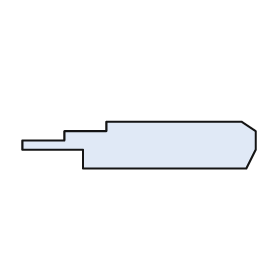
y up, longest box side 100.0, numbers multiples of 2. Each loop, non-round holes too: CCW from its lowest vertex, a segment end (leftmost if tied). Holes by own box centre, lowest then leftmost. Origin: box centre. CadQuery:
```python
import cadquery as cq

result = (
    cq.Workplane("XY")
    .moveTo(-24.0, -10.0)
    .lineTo(46.0, -10.0)
    .lineTo(50.0, -2.0)
    .lineTo(50.0, 6.0)
    .lineTo(44.0, 10.0)
    .lineTo(-14.0, 10.0)
    .lineTo(-14.0, 6.0)
    .lineTo(-32.0, 6.0)
    .lineTo(-32.0, 2.0)
    .lineTo(-50.0, 2.0)
    .lineTo(-50.0, -2.0)
    .lineTo(-24.0, -2.0)
    .close()
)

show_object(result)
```